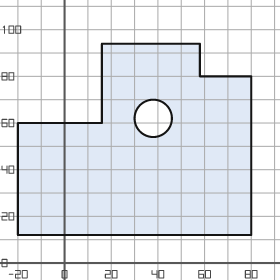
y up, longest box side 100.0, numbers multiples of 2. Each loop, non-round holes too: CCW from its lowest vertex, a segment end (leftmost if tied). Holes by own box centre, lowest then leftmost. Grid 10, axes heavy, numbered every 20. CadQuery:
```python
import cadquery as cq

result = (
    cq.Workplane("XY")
    .moveTo(-20.0, 12.0)
    .lineTo(80.0, 12.0)
    .lineTo(80.0, 80.0)
    .lineTo(58.0, 80.0)
    .lineTo(58.0, 94.0)
    .lineTo(16.0, 94.0)
    .lineTo(16.0, 60.0)
    .lineTo(-20.0, 60.0)
    .close()
    .moveTo(38.0, 62.0)
    .circle(8.0)
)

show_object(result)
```